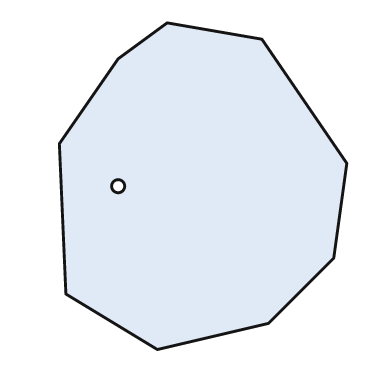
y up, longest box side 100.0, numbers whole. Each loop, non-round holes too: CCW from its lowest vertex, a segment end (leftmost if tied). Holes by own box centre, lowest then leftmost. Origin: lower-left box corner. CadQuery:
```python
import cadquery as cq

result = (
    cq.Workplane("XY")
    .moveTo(30.0, 0.0)
    .lineTo(64.0, 8.0)
    .lineTo(84.0, 28.0)
    .lineTo(88.0, 57.0)
    .lineTo(62.0, 95.0)
    .lineTo(33.0, 100.0)
    .lineTo(18.0, 89.0)
    .lineTo(0.0, 63.0)
    .lineTo(2.0, 17.0)
    .close()
    .moveTo(18.0, 50.0)
    .circle(2.0)
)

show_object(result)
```